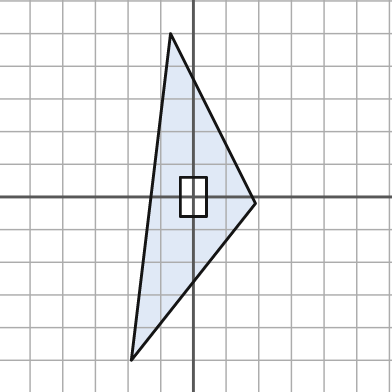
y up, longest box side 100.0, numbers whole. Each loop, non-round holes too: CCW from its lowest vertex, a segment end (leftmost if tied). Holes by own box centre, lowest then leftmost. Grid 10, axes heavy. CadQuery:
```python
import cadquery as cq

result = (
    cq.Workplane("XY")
    .moveTo(-19.0, -50.0)
    .lineTo(19.0, -2.0)
    .lineTo(-7.0, 50.0)
    .close()
    .moveTo(-4.0, -6.0)
    .lineTo(4.0, -6.0)
    .lineTo(4.0, 6.0)
    .lineTo(-4.0, 6.0)
    .close()
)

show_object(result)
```